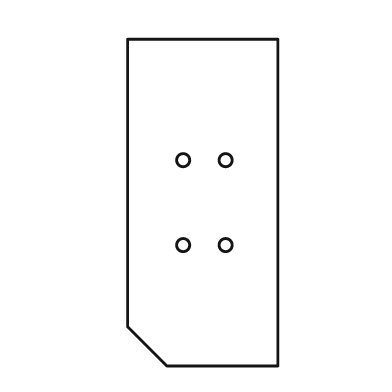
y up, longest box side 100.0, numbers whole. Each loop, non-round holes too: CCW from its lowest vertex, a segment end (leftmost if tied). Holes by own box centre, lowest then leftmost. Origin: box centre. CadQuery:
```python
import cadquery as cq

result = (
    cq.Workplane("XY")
    .moveTo(-11.0, -50.0)
    .lineTo(23.0, -50.0)
    .lineTo(23.0, 50.0)
    .lineTo(-23.0, 50.0)
    .lineTo(-23.0, -38.0)
    .close()
    .moveTo(-6.0, -13.0)
    .circle(2.0)
    .moveTo(7.0, -13.0)
    .circle(2.0)
    .moveTo(-6.0, 13.0)
    .circle(2.0)
    .moveTo(7.0, 13.0)
    .circle(2.0)
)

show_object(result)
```